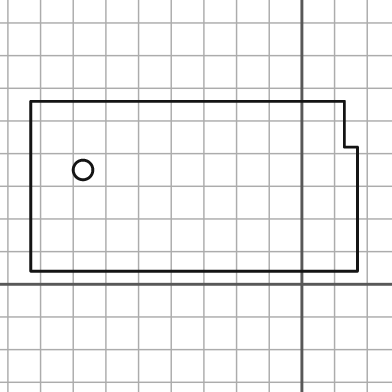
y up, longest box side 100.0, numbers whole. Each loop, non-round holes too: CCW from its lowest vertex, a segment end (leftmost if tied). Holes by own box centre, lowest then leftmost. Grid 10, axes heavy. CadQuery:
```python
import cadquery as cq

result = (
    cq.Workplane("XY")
    .moveTo(-83.0, 4.0)
    .lineTo(17.0, 4.0)
    .lineTo(17.0, 42.0)
    .lineTo(13.0, 42.0)
    .lineTo(13.0, 56.0)
    .lineTo(-83.0, 56.0)
    .close()
    .moveTo(-67.0, 35.0)
    .circle(3.0)
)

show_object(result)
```